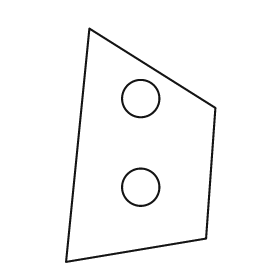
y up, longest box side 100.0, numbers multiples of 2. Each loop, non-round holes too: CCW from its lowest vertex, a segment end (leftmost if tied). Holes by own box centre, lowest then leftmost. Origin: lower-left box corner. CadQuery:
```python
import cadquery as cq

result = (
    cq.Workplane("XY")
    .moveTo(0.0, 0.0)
    .lineTo(60.0, 10.0)
    .lineTo(64.0, 66.0)
    .lineTo(10.0, 100.0)
    .close()
    .moveTo(32.0, 32.0)
    .circle(8.0)
    .moveTo(32.0, 70.0)
    .circle(8.0)
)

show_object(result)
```